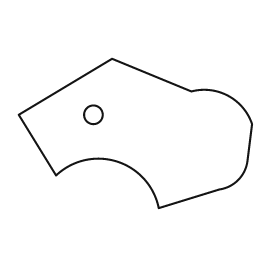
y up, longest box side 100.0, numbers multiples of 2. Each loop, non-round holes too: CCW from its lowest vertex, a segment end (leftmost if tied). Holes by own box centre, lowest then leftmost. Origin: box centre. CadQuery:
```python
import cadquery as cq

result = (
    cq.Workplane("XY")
    .moveTo(10.0, -32.0)
    .lineTo(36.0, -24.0)
    .threePointArc((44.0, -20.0), (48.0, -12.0))
    .lineTo(50.0, 4.0)
    .threePointArc((40.0, 16.0), (24.0, 18.0))
    .lineTo(-10.0, 32.0)
    .lineTo(-50.0, 8.0)
    .lineTo(-34.0, -18.0)
    .threePointArc((-8.0, -12.0), (10.0, -32.0))
    .close()
    .moveTo(-18.0, 8.0)
    .circle(4.0)
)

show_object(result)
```